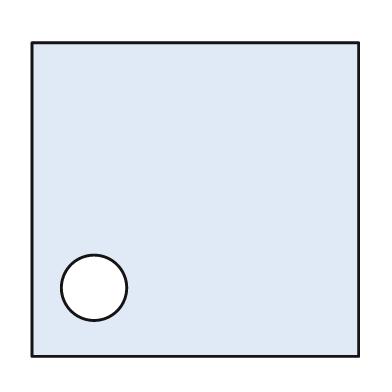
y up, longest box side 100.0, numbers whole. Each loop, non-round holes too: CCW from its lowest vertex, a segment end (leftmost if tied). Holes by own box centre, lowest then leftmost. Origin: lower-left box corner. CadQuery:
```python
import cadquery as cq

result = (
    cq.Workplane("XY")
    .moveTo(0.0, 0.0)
    .lineTo(100.0, 0.0)
    .lineTo(100.0, 96.0)
    .lineTo(0.0, 96.0)
    .close()
    .moveTo(19.0, 21.0)
    .circle(10.0)
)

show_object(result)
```